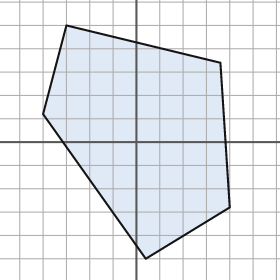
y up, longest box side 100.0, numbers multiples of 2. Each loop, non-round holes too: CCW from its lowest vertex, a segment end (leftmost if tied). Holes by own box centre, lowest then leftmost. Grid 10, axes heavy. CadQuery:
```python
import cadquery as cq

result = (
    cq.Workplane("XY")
    .moveTo(4.0, -50.0)
    .lineTo(40.0, -28.0)
    .lineTo(36.0, 34.0)
    .lineTo(-30.0, 50.0)
    .lineTo(-40.0, 12.0)
    .close()
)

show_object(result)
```